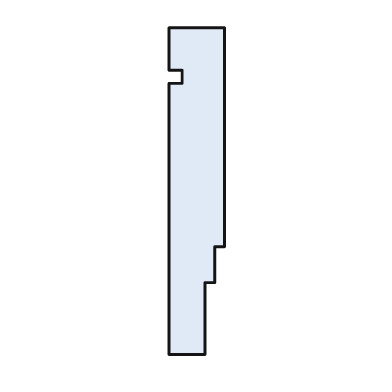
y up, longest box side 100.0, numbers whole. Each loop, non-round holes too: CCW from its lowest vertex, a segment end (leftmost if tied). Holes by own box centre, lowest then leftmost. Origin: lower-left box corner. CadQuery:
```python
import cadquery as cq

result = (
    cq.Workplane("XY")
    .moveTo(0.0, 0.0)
    .lineTo(11.0, 0.0)
    .lineTo(11.0, 22.0)
    .lineTo(14.0, 22.0)
    .lineTo(14.0, 33.0)
    .lineTo(17.0, 33.0)
    .lineTo(17.0, 100.0)
    .lineTo(0.0, 100.0)
    .lineTo(0.0, 87.0)
    .lineTo(4.0, 87.0)
    .lineTo(4.0, 83.0)
    .lineTo(0.0, 83.0)
    .close()
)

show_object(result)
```